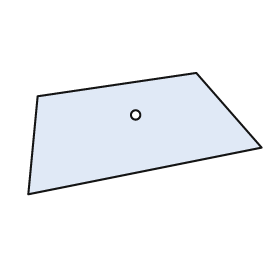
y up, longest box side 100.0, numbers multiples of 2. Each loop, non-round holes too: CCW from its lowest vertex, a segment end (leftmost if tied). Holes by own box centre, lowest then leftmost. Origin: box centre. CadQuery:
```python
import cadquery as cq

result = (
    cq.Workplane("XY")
    .moveTo(-50.0, -26.0)
    .lineTo(50.0, -6.0)
    .lineTo(22.0, 26.0)
    .lineTo(-46.0, 16.0)
    .close()
    .moveTo(-4.0, 8.0)
    .circle(2.0)
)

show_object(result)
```